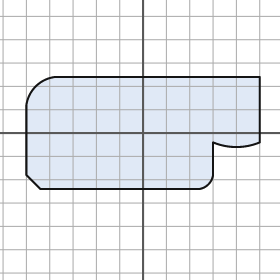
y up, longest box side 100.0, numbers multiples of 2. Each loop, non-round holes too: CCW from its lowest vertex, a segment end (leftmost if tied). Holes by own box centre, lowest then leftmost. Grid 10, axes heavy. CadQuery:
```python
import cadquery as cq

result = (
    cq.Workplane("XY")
    .moveTo(-44.0, -24.0)
    .lineTo(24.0, -24.0)
    .threePointArc((28.0, -22.0), (30.0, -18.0))
    .lineTo(30.0, -4.0)
    .threePointArc((40.0, -6.0), (50.0, -4.0))
    .lineTo(50.0, 24.0)
    .lineTo(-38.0, 24.0)
    .threePointArc((-46.0, 20.0), (-50.0, 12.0))
    .lineTo(-50.0, -18.0)
    .close()
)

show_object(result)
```